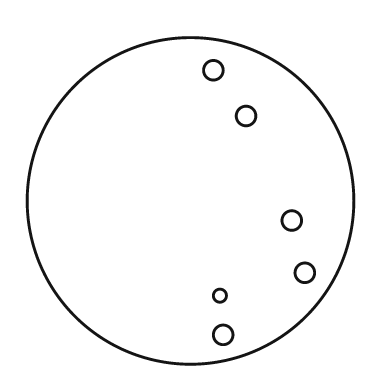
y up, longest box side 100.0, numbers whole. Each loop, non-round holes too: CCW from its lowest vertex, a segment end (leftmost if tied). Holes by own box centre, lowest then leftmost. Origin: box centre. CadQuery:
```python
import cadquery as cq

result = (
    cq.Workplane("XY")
    .moveTo(0.0, 0.0)
    .circle(50.0)
    .moveTo(10.0, -41.0)
    .circle(3.0)
    .moveTo(9.0, -29.0)
    .circle(2.0)
    .moveTo(35.0, -22.0)
    .circle(3.0)
    .moveTo(31.0, -6.0)
    .circle(3.0)
    .moveTo(17.0, 26.0)
    .circle(3.0)
    .moveTo(7.0, 40.0)
    .circle(3.0)
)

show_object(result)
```